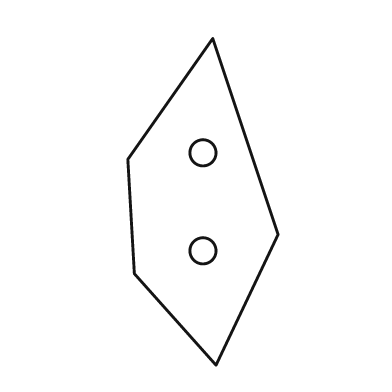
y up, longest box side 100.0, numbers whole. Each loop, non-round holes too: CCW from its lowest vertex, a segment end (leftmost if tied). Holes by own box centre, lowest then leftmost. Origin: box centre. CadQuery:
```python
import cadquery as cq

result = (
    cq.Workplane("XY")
    .moveTo(4.0, -50.0)
    .lineTo(23.0, -10.0)
    .lineTo(3.0, 50.0)
    .lineTo(-23.0, 13.0)
    .lineTo(-21.0, -22.0)
    .close()
    .moveTo(0.0, -15.0)
    .circle(4.0)
    .moveTo(0.0, 15.0)
    .circle(4.0)
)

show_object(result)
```